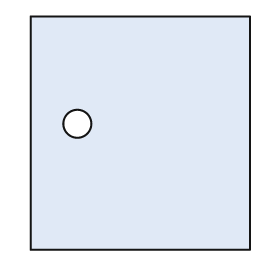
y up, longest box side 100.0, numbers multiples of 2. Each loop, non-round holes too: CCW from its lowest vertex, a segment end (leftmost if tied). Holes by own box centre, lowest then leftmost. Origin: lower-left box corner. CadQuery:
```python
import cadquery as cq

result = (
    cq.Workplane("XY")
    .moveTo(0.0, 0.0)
    .lineTo(94.0, 0.0)
    .lineTo(94.0, 100.0)
    .lineTo(0.0, 100.0)
    .close()
    .moveTo(20.0, 54.0)
    .circle(6.0)
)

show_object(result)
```